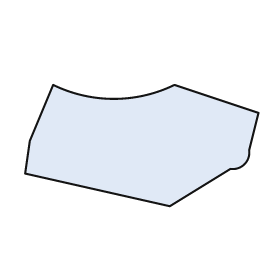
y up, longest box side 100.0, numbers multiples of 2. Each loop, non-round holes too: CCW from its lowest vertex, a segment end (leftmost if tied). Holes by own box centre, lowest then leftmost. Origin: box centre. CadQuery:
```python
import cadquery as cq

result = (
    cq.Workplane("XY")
    .moveTo(12.0, -26.0)
    .lineTo(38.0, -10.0)
    .threePointArc((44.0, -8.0), (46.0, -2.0))
    .lineTo(50.0, 14.0)
    .lineTo(14.0, 26.0)
    .threePointArc((-12.0, 20.0), (-38.0, 26.0))
    .lineTo(-48.0, 2.0)
    .lineTo(-50.0, -12.0)
    .close()
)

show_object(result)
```